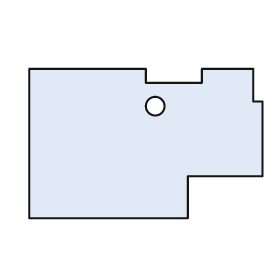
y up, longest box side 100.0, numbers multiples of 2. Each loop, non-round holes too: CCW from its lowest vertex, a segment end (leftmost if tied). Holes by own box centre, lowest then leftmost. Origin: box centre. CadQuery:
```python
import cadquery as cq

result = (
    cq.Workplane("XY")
    .moveTo(-50.0, -32.0)
    .lineTo(18.0, -32.0)
    .lineTo(18.0, -14.0)
    .lineTo(50.0, -14.0)
    .lineTo(50.0, 18.0)
    .lineTo(46.0, 18.0)
    .lineTo(46.0, 32.0)
    .lineTo(24.0, 32.0)
    .lineTo(24.0, 26.0)
    .lineTo(0.0, 26.0)
    .lineTo(0.0, 32.0)
    .lineTo(-50.0, 32.0)
    .close()
    .moveTo(4.0, 16.0)
    .circle(4.0)
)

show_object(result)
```